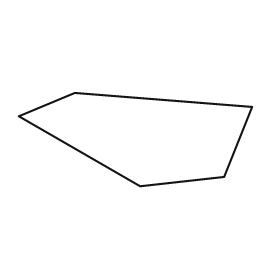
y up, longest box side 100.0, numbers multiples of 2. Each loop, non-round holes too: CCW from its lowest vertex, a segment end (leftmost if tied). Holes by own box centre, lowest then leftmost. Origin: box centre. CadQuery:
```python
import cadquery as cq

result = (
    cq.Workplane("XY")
    .moveTo(2.0, -20.0)
    .lineTo(38.0, -16.0)
    .lineTo(50.0, 14.0)
    .lineTo(-26.0, 20.0)
    .lineTo(-50.0, 10.0)
    .close()
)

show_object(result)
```